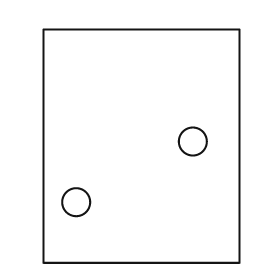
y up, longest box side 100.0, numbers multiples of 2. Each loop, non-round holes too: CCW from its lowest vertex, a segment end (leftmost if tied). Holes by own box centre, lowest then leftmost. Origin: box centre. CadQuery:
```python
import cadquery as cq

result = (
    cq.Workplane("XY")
    .moveTo(-42.0, -50.0)
    .lineTo(42.0, -50.0)
    .lineTo(42.0, 50.0)
    .lineTo(-42.0, 50.0)
    .close()
    .moveTo(-28.0, -24.0)
    .circle(6.0)
    .moveTo(22.0, 2.0)
    .circle(6.0)
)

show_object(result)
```